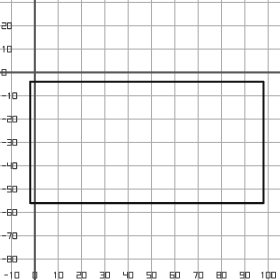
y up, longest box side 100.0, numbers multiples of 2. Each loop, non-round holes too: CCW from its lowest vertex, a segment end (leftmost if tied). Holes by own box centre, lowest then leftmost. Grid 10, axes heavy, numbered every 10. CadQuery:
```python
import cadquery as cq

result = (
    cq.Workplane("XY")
    .moveTo(-2.0, -56.0)
    .lineTo(98.0, -56.0)
    .lineTo(98.0, -4.0)
    .lineTo(-2.0, -4.0)
    .close()
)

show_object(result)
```